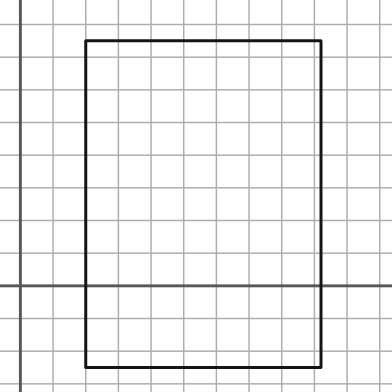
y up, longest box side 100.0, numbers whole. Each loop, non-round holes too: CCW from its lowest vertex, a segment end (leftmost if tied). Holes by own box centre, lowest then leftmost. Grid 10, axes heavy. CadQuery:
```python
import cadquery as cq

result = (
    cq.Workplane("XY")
    .moveTo(20.0, -25.0)
    .lineTo(92.0, -25.0)
    .lineTo(92.0, 75.0)
    .lineTo(20.0, 75.0)
    .close()
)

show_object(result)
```